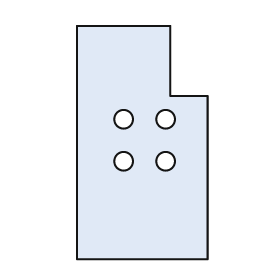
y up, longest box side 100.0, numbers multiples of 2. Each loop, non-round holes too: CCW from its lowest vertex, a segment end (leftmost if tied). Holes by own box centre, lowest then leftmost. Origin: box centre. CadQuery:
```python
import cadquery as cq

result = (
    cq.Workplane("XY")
    .moveTo(-28.0, -50.0)
    .lineTo(28.0, -50.0)
    .lineTo(28.0, 20.0)
    .lineTo(12.0, 20.0)
    .lineTo(12.0, 50.0)
    .lineTo(-28.0, 50.0)
    .close()
    .moveTo(-8.0, -8.0)
    .circle(4.0)
    .moveTo(10.0, -8.0)
    .circle(4.0)
    .moveTo(-8.0, 10.0)
    .circle(4.0)
    .moveTo(10.0, 10.0)
    .circle(4.0)
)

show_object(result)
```